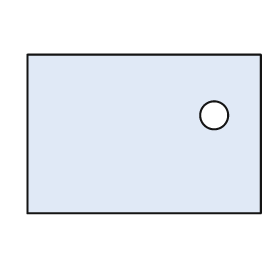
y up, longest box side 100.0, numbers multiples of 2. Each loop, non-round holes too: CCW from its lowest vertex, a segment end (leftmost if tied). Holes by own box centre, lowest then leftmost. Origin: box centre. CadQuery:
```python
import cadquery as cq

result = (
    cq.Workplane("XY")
    .moveTo(-50.0, -34.0)
    .lineTo(50.0, -34.0)
    .lineTo(50.0, 34.0)
    .lineTo(-50.0, 34.0)
    .close()
    .moveTo(30.0, 8.0)
    .circle(6.0)
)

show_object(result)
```